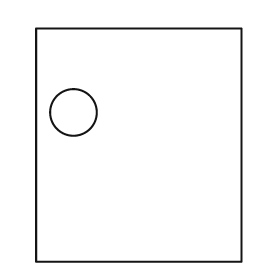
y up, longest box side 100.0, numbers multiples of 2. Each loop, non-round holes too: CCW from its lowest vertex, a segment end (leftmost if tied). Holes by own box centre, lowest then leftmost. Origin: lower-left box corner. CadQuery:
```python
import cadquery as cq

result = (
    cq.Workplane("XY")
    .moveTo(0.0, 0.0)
    .lineTo(88.0, 0.0)
    .lineTo(88.0, 100.0)
    .lineTo(0.0, 100.0)
    .close()
    .moveTo(16.0, 64.0)
    .circle(10.0)
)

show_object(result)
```